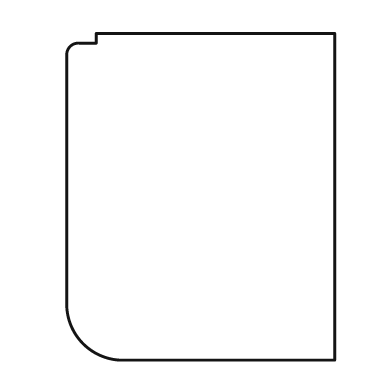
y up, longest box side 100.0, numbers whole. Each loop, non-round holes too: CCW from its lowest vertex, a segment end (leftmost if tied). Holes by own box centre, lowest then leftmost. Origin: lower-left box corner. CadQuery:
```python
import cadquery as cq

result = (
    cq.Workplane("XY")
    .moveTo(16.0, 0.0)
    .lineTo(82.0, 0.0)
    .lineTo(82.0, 100.0)
    .lineTo(9.0, 100.0)
    .lineTo(9.0, 97.0)
    .lineTo(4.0, 97.0)
    .threePointArc((1.0, 96.0), (0.0, 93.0))
    .lineTo(0.0, 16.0)
    .threePointArc((5.0, 5.0), (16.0, 0.0))
    .close()
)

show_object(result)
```